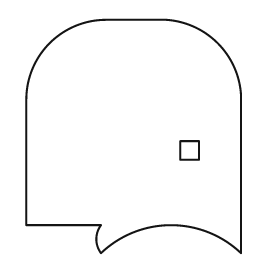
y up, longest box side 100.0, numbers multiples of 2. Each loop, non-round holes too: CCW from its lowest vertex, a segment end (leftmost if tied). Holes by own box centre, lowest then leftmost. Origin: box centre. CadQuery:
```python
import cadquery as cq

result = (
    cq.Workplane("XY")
    .moveTo(-14.0, -50.0)
    .threePointArc((16.0, -38.0), (46.0, -50.0))
    .lineTo(46.0, 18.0)
    .threePointArc((36.0, 40.0), (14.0, 50.0))
    .lineTo(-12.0, 50.0)
    .threePointArc((-36.0, 40.0), (-46.0, 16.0))
    .lineTo(-46.0, -38.0)
    .lineTo(-14.0, -38.0)
    .threePointArc((-16.0, -44.0), (-14.0, -50.0))
    .close()
    .moveTo(20.0, -10.0)
    .lineTo(28.0, -10.0)
    .lineTo(28.0, -2.0)
    .lineTo(20.0, -2.0)
    .close()
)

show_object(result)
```